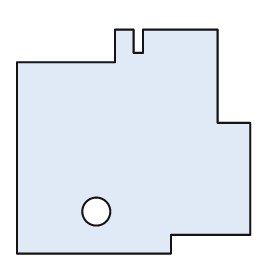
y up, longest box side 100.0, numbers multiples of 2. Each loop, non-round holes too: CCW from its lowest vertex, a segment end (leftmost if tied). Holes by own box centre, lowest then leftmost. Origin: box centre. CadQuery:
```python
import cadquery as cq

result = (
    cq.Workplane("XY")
    .moveTo(-50.0, -48.0)
    .lineTo(16.0, -48.0)
    .lineTo(16.0, -40.0)
    .lineTo(50.0, -40.0)
    .lineTo(50.0, 8.0)
    .lineTo(36.0, 8.0)
    .lineTo(36.0, 48.0)
    .lineTo(4.0, 48.0)
    .lineTo(4.0, 38.0)
    .lineTo(0.0, 38.0)
    .lineTo(0.0, 48.0)
    .lineTo(-8.0, 48.0)
    .lineTo(-8.0, 34.0)
    .lineTo(-50.0, 34.0)
    .close()
    .moveTo(-16.0, -30.0)
    .circle(6.0)
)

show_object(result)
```